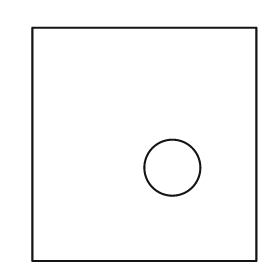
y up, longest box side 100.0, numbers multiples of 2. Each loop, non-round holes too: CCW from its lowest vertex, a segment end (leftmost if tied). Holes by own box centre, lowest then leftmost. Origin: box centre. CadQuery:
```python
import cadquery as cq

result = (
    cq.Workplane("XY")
    .moveTo(-48.0, -50.0)
    .lineTo(48.0, -50.0)
    .lineTo(48.0, 50.0)
    .lineTo(-48.0, 50.0)
    .close()
    .moveTo(12.0, -10.0)
    .circle(12.0)
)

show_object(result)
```